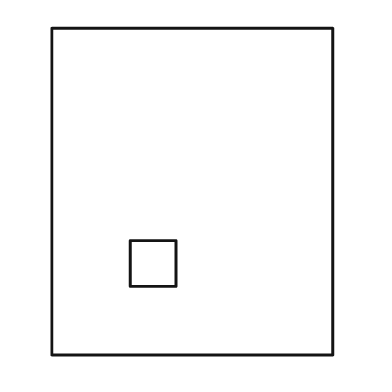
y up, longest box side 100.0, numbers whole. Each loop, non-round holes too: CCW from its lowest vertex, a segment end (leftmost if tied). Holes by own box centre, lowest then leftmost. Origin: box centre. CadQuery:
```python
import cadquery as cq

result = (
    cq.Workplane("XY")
    .moveTo(-43.0, -50.0)
    .lineTo(43.0, -50.0)
    .lineTo(43.0, 50.0)
    .lineTo(-43.0, 50.0)
    .close()
    .moveTo(-19.0, -29.0)
    .lineTo(-5.0, -29.0)
    .lineTo(-5.0, -15.0)
    .lineTo(-19.0, -15.0)
    .close()
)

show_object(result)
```